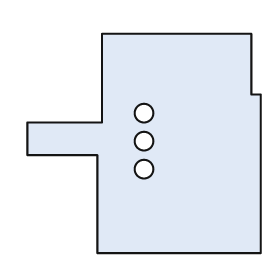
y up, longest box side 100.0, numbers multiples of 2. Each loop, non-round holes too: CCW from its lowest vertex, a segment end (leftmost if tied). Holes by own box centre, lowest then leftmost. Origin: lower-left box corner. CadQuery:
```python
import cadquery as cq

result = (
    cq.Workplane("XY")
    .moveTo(30.0, 0.0)
    .lineTo(100.0, 0.0)
    .lineTo(100.0, 68.0)
    .lineTo(96.0, 68.0)
    .lineTo(96.0, 94.0)
    .lineTo(32.0, 94.0)
    .lineTo(32.0, 56.0)
    .lineTo(0.0, 56.0)
    .lineTo(0.0, 42.0)
    .lineTo(30.0, 42.0)
    .close()
    .moveTo(50.0, 36.0)
    .circle(4.0)
    .moveTo(50.0, 48.0)
    .circle(4.0)
    .moveTo(50.0, 60.0)
    .circle(4.0)
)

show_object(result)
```